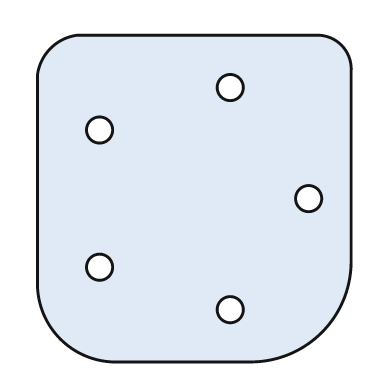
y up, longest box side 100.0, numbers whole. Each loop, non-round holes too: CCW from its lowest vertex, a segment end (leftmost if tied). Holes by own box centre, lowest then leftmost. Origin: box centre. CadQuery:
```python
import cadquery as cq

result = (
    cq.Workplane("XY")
    .moveTo(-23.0, -50.0)
    .lineTo(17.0, -50.0)
    .threePointArc((39.0, -41.0), (48.0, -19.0))
    .lineTo(48.0, 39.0)
    .threePointArc((45.0, 47.0), (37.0, 50.0))
    .lineTo(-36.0, 50.0)
    .threePointArc((-44.0, 46.0), (-48.0, 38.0))
    .lineTo(-48.0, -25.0)
    .threePointArc((-41.0, -43.0), (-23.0, -50.0))
    .close()
    .moveTo(11.0, -34.0)
    .circle(4.0)
    .moveTo(-29.0, -21.0)
    .circle(4.0)
    .moveTo(35.0, 0.0)
    .circle(4.0)
    .moveTo(-29.0, 21.0)
    .circle(4.0)
    .moveTo(11.0, 34.0)
    .circle(4.0)
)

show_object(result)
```